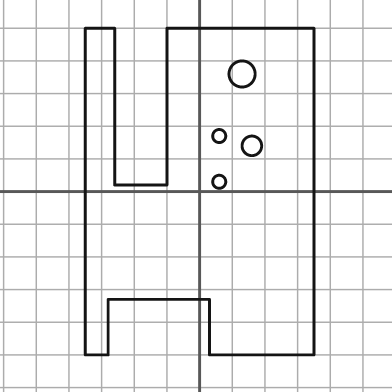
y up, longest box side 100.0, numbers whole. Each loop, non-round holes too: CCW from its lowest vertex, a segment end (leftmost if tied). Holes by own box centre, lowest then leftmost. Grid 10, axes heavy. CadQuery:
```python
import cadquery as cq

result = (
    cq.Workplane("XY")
    .moveTo(-35.0, -50.0)
    .lineTo(-28.0, -50.0)
    .lineTo(-28.0, -33.0)
    .lineTo(3.0, -33.0)
    .lineTo(3.0, -50.0)
    .lineTo(35.0, -50.0)
    .lineTo(35.0, 50.0)
    .lineTo(-10.0, 50.0)
    .lineTo(-10.0, 2.0)
    .lineTo(-26.0, 2.0)
    .lineTo(-26.0, 50.0)
    .lineTo(-35.0, 50.0)
    .close()
    .moveTo(6.0, 3.0)
    .circle(2.0)
    .moveTo(16.0, 14.0)
    .circle(3.0)
    .moveTo(6.0, 17.0)
    .circle(2.0)
    .moveTo(13.0, 36.0)
    .circle(4.0)
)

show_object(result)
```